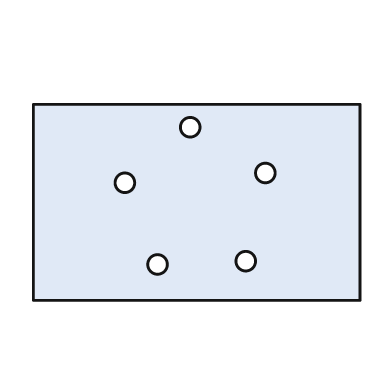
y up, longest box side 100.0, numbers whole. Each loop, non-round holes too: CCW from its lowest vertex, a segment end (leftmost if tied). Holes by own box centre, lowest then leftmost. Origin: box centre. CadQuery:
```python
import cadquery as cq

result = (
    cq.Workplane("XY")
    .moveTo(-50.0, -30.0)
    .lineTo(50.0, -30.0)
    .lineTo(50.0, 30.0)
    .lineTo(-50.0, 30.0)
    .close()
    .moveTo(-12.0, -19.0)
    .circle(3.0)
    .moveTo(15.0, -18.0)
    .circle(3.0)
    .moveTo(-22.0, 6.0)
    .circle(3.0)
    .moveTo(21.0, 9.0)
    .circle(3.0)
    .moveTo(-2.0, 23.0)
    .circle(3.0)
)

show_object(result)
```